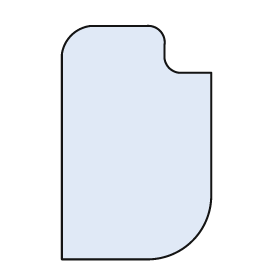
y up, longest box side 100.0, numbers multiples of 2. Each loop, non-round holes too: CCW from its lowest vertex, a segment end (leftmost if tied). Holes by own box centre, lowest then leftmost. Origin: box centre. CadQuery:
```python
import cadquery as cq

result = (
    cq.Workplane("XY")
    .moveTo(-32.0, -50.0)
    .lineTo(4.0, -50.0)
    .threePointArc((24.0, -42.0), (32.0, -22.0))
    .lineTo(32.0, 30.0)
    .lineTo(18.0, 30.0)
    .threePointArc((14.0, 32.0), (12.0, 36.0))
    .lineTo(12.0, 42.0)
    .threePointArc((10.0, 48.0), (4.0, 50.0))
    .lineTo(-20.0, 50.0)
    .threePointArc((-28.0, 46.0), (-32.0, 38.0))
    .close()
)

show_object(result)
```